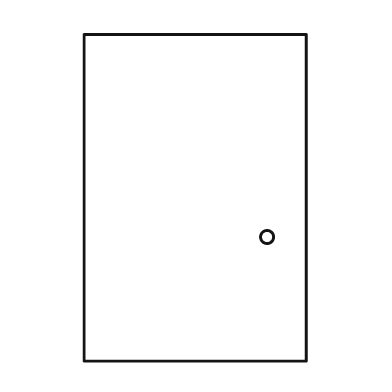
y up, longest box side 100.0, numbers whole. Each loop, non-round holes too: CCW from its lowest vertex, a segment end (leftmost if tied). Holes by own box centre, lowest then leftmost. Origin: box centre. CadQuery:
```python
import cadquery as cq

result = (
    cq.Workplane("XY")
    .moveTo(-34.0, -50.0)
    .lineTo(34.0, -50.0)
    .lineTo(34.0, 50.0)
    .lineTo(-34.0, 50.0)
    .close()
    .moveTo(22.0, -12.0)
    .circle(2.0)
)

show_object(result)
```